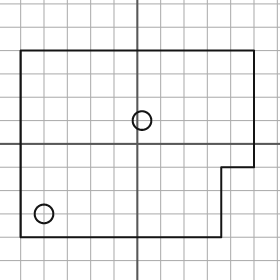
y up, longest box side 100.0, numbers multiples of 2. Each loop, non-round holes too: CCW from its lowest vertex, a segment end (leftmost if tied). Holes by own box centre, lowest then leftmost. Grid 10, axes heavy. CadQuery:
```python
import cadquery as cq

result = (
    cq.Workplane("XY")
    .moveTo(-50.0, -40.0)
    .lineTo(36.0, -40.0)
    .lineTo(36.0, -10.0)
    .lineTo(50.0, -10.0)
    .lineTo(50.0, 40.0)
    .lineTo(-50.0, 40.0)
    .close()
    .moveTo(-40.0, -30.0)
    .circle(4.0)
    .moveTo(2.0, 10.0)
    .circle(4.0)
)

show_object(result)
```